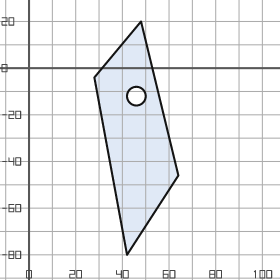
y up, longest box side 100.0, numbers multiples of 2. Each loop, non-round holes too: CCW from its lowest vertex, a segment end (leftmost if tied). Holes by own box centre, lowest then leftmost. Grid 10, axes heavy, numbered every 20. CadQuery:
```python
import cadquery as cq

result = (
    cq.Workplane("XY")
    .moveTo(42.0, -80.0)
    .lineTo(64.0, -46.0)
    .lineTo(48.0, 20.0)
    .lineTo(28.0, -4.0)
    .close()
    .moveTo(46.0, -12.0)
    .circle(4.0)
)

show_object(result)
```